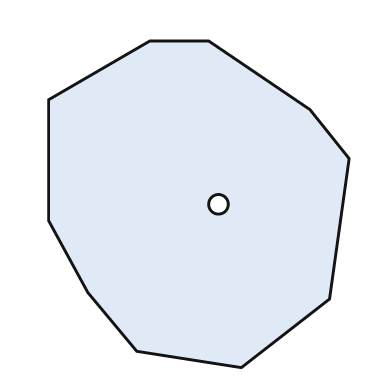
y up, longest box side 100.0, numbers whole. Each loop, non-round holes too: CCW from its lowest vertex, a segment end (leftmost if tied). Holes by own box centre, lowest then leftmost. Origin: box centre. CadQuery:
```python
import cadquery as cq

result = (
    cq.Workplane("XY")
    .moveTo(13.0, -50.0)
    .lineTo(40.0, -29.0)
    .lineTo(46.0, 14.0)
    .lineTo(34.0, 29.0)
    .lineTo(3.0, 50.0)
    .lineTo(-15.0, 50.0)
    .lineTo(-46.0, 32.0)
    .lineTo(-46.0, -5.0)
    .lineTo(-34.0, -27.0)
    .lineTo(-19.0, -45.0)
    .close()
    .moveTo(6.0, 0.0)
    .circle(3.0)
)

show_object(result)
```